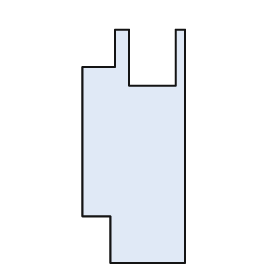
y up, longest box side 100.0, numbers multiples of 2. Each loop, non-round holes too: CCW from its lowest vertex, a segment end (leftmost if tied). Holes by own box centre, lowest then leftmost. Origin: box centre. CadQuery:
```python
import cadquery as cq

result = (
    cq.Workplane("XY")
    .moveTo(-10.0, -50.0)
    .lineTo(22.0, -50.0)
    .lineTo(22.0, 50.0)
    .lineTo(18.0, 50.0)
    .lineTo(18.0, 26.0)
    .lineTo(-2.0, 26.0)
    .lineTo(-2.0, 50.0)
    .lineTo(-8.0, 50.0)
    .lineTo(-8.0, 34.0)
    .lineTo(-22.0, 34.0)
    .lineTo(-22.0, -30.0)
    .lineTo(-10.0, -30.0)
    .close()
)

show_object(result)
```